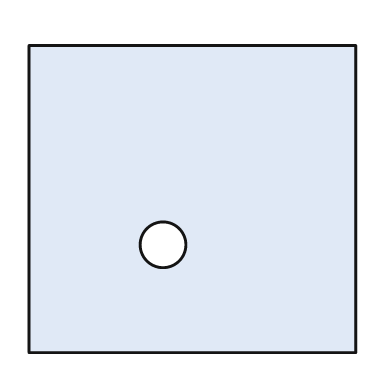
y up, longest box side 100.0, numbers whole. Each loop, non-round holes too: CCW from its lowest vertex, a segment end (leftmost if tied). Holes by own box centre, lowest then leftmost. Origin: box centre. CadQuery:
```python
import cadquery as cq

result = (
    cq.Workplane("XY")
    .moveTo(-50.0, -47.0)
    .lineTo(50.0, -47.0)
    .lineTo(50.0, 47.0)
    .lineTo(-50.0, 47.0)
    .close()
    .moveTo(-9.0, -14.0)
    .circle(7.0)
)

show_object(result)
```